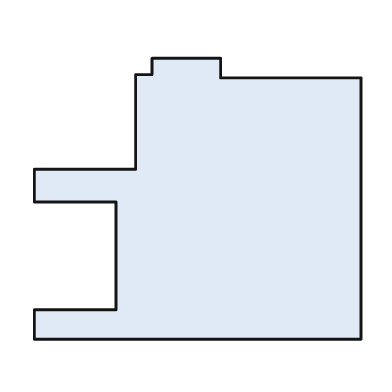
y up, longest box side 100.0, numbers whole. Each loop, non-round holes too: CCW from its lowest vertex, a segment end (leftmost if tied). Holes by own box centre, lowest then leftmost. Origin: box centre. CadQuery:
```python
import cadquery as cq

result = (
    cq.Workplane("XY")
    .moveTo(-50.0, -43.0)
    .lineTo(50.0, -43.0)
    .lineTo(50.0, 37.0)
    .lineTo(7.0, 37.0)
    .lineTo(7.0, 43.0)
    .lineTo(-14.0, 43.0)
    .lineTo(-14.0, 38.0)
    .lineTo(-19.0, 38.0)
    .lineTo(-19.0, 9.0)
    .lineTo(-50.0, 9.0)
    .lineTo(-50.0, -1.0)
    .lineTo(-25.0, -1.0)
    .lineTo(-25.0, -34.0)
    .lineTo(-50.0, -34.0)
    .close()
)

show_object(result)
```